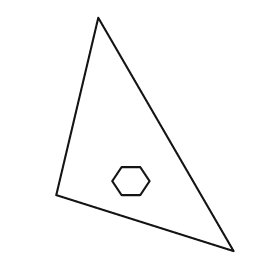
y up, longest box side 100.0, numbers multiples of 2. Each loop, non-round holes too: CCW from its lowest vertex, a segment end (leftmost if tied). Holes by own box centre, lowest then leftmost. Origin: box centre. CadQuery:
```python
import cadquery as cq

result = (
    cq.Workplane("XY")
    .moveTo(38.0, -50.0)
    .lineTo(-20.0, 50.0)
    .lineTo(-38.0, -26.0)
    .close()
    .moveTo(-10.0, -26.0)
    .lineTo(-2.0, -26.0)
    .lineTo(2.0, -20.0)
    .lineTo(-2.0, -14.0)
    .lineTo(-10.0, -14.0)
    .lineTo(-14.0, -20.0)
    .close()
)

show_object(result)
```